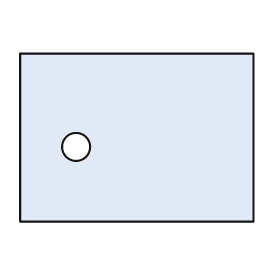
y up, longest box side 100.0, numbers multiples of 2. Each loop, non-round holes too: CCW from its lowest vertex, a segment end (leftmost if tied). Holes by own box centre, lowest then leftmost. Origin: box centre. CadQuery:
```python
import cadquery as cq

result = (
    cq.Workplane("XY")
    .moveTo(-50.0, -36.0)
    .lineTo(50.0, -36.0)
    .lineTo(50.0, 36.0)
    .lineTo(-50.0, 36.0)
    .close()
    .moveTo(-26.0, -4.0)
    .circle(6.0)
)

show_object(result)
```